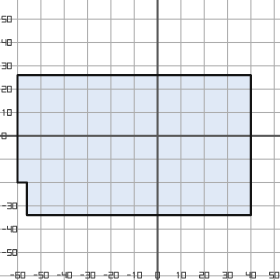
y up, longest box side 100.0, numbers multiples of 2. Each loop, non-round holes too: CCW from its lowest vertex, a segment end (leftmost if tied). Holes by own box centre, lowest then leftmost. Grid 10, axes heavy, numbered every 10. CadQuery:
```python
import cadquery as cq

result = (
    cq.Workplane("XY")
    .moveTo(-56.0, -34.0)
    .lineTo(40.0, -34.0)
    .lineTo(40.0, 26.0)
    .lineTo(-60.0, 26.0)
    .lineTo(-60.0, -20.0)
    .lineTo(-56.0, -20.0)
    .close()
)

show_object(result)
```